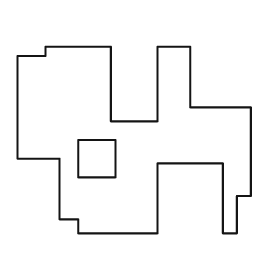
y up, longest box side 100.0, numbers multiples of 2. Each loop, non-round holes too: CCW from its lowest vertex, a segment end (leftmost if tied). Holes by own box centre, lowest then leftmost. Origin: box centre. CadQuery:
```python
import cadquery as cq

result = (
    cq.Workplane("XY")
    .moveTo(-24.0, -40.0)
    .lineTo(10.0, -40.0)
    .lineTo(10.0, -10.0)
    .lineTo(38.0, -10.0)
    .lineTo(38.0, -40.0)
    .lineTo(44.0, -40.0)
    .lineTo(44.0, -24.0)
    .lineTo(50.0, -24.0)
    .lineTo(50.0, 14.0)
    .lineTo(24.0, 14.0)
    .lineTo(24.0, 40.0)
    .lineTo(10.0, 40.0)
    .lineTo(10.0, 8.0)
    .lineTo(-10.0, 8.0)
    .lineTo(-10.0, 40.0)
    .lineTo(-38.0, 40.0)
    .lineTo(-38.0, 36.0)
    .lineTo(-50.0, 36.0)
    .lineTo(-50.0, -8.0)
    .lineTo(-32.0, -8.0)
    .lineTo(-32.0, -34.0)
    .lineTo(-24.0, -34.0)
    .close()
    .moveTo(-24.0, -16.0)
    .lineTo(-8.0, -16.0)
    .lineTo(-8.0, 0.0)
    .lineTo(-24.0, 0.0)
    .close()
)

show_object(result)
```